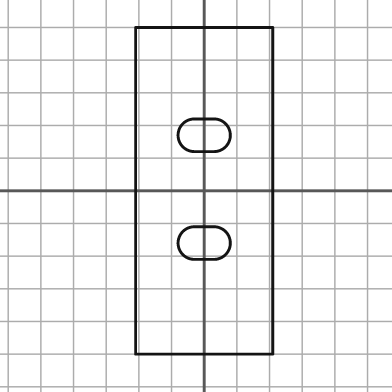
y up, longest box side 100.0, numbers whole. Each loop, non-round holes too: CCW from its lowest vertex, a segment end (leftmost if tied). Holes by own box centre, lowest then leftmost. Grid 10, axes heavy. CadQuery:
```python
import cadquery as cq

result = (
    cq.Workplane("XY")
    .moveTo(-21.0, -50.0)
    .lineTo(21.0, -50.0)
    .lineTo(21.0, 50.0)
    .lineTo(-21.0, 50.0)
    .close()
    .moveTo(-3.0, -21.0)
    .lineTo(3.0, -21.0)
    .threePointArc((8.0, -16.0), (3.0, -11.0))
    .lineTo(-3.0, -11.0)
    .threePointArc((-8.0, -16.0), (-3.0, -21.0))
    .close()
    .moveTo(-3.0, 12.0)
    .lineTo(3.0, 12.0)
    .threePointArc((8.0, 17.0), (3.0, 22.0))
    .lineTo(-3.0, 22.0)
    .threePointArc((-8.0, 17.0), (-3.0, 12.0))
    .close()
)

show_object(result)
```